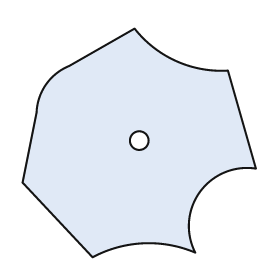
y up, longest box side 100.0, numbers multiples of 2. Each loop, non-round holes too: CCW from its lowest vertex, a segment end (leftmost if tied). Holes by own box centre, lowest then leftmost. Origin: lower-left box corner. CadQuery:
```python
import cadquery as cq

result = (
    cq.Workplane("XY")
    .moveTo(30.0, 0.0)
    .threePointArc((52.0, 6.0), (74.0, 2.0))
    .threePointArc((76.0, 28.0), (100.0, 38.0))
    .lineTo(88.0, 80.0)
    .threePointArc((66.0, 84.0), (48.0, 98.0))
    .lineTo(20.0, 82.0)
    .threePointArc((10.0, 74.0), (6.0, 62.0))
    .lineTo(0.0, 32.0)
    .close()
    .moveTo(50.0, 50.0)
    .circle(4.0)
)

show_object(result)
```